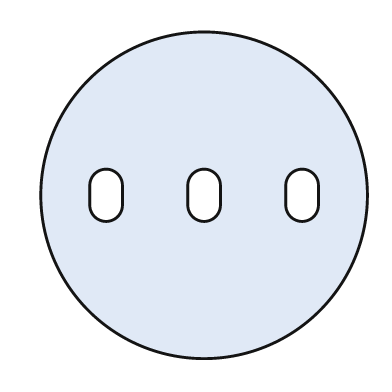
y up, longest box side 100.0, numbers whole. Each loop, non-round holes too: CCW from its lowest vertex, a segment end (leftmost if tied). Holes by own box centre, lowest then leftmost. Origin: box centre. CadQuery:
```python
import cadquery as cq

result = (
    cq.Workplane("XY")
    .moveTo(0.0, 0.0)
    .circle(50.0)
    .moveTo(-35.0, -3.0)
    .threePointArc((-30.0, -8.0), (-25.0, -3.0))
    .lineTo(-25.0, 3.0)
    .threePointArc((-30.0, 8.0), (-35.0, 3.0))
    .close()
    .moveTo(-5.0, -3.0)
    .threePointArc((0.0, -8.0), (5.0, -3.0))
    .lineTo(5.0, 3.0)
    .threePointArc((0.0, 8.0), (-5.0, 3.0))
    .close()
    .moveTo(25.0, -3.0)
    .threePointArc((30.0, -8.0), (35.0, -3.0))
    .lineTo(35.0, 3.0)
    .threePointArc((30.0, 8.0), (25.0, 3.0))
    .close()
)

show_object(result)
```